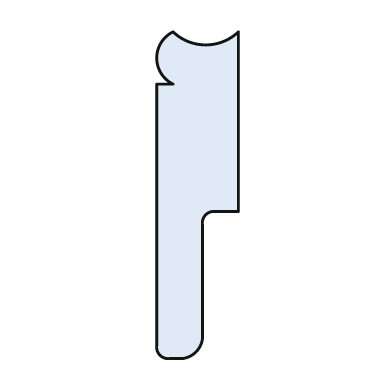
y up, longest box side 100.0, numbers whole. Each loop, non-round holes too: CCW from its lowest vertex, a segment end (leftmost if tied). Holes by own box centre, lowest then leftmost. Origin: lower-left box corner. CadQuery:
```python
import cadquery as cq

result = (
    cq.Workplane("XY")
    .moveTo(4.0, 0.0)
    .lineTo(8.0, 0.0)
    .threePointArc((12.0, 2.0), (14.0, 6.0))
    .lineTo(14.0, 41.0)
    .threePointArc((15.0, 44.0), (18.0, 45.0))
    .lineTo(25.0, 45.0)
    .lineTo(25.0, 100.0)
    .threePointArc((15.0, 96.0), (5.0, 100.0))
    .threePointArc((0.0, 92.0), (5.0, 84.0))
    .lineTo(0.0, 84.0)
    .lineTo(0.0, 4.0)
    .threePointArc((1.0, 1.0), (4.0, 0.0))
    .close()
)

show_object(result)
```